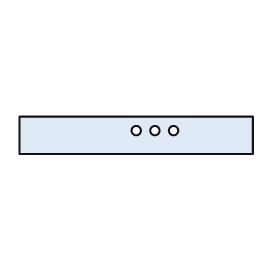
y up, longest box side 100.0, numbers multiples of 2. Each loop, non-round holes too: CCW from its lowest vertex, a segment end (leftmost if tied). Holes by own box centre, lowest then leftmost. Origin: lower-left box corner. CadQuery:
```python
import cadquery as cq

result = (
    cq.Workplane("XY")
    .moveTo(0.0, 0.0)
    .lineTo(100.0, 0.0)
    .lineTo(100.0, 16.0)
    .lineTo(0.0, 16.0)
    .close()
    .moveTo(50.0, 10.0)
    .circle(2.0)
    .moveTo(58.0, 10.0)
    .circle(2.0)
    .moveTo(66.0, 10.0)
    .circle(2.0)
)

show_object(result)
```